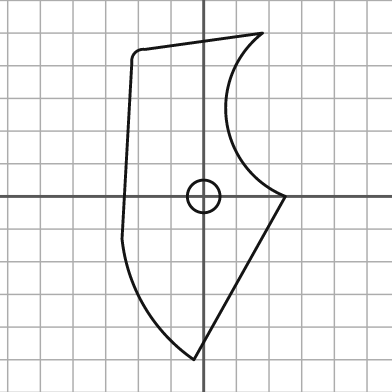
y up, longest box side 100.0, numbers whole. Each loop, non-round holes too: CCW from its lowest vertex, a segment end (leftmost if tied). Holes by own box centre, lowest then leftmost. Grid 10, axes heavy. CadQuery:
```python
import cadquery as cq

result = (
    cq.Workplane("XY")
    .moveTo(-3.0, -50.0)
    .lineTo(25.0, 0.0)
    .threePointArc((7.0, 23.0), (18.0, 50.0))
    .lineTo(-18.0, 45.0)
    .threePointArc((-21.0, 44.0), (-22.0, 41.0))
    .lineTo(-25.0, -13.0)
    .threePointArc((-18.0, -34.0), (-3.0, -50.0))
    .close()
    .moveTo(0.0, 0.0)
    .circle(5.0)
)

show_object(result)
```